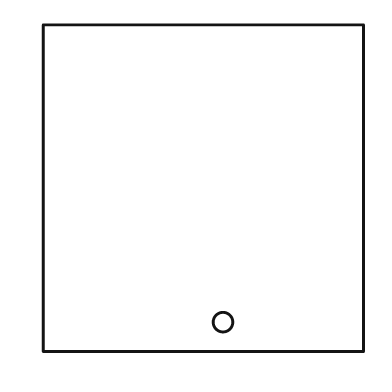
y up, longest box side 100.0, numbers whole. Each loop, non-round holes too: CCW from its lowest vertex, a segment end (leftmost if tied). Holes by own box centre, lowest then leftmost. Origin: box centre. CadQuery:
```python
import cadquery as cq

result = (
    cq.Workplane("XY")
    .moveTo(-49.0, -50.0)
    .lineTo(49.0, -50.0)
    .lineTo(49.0, 50.0)
    .lineTo(-49.0, 50.0)
    .close()
    .moveTo(6.0, -41.0)
    .circle(3.0)
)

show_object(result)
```